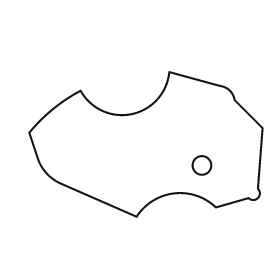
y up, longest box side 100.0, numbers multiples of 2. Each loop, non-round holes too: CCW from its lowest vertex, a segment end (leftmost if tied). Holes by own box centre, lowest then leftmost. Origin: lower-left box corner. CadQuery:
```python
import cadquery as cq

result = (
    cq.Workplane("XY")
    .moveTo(46.0, 0.0)
    .threePointArc((62.0, 10.0), (80.0, 4.0))
    .lineTo(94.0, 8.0)
    .threePointArc((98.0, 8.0), (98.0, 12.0))
    .lineTo(100.0, 38.0)
    .lineTo(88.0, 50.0)
    .threePointArc((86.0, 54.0), (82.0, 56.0))
    .lineTo(60.0, 62.0)
    .threePointArc((44.0, 44.0), (22.0, 54.0))
    .threePointArc((10.0, 46.0), (0.0, 36.0))
    .lineTo(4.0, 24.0)
    .threePointArc((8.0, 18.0), (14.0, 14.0))
    .close()
    .moveTo(74.0, 22.0)
    .circle(4.0)
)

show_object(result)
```